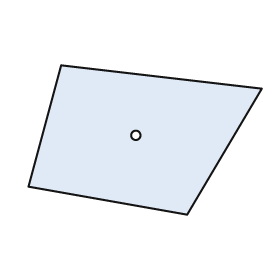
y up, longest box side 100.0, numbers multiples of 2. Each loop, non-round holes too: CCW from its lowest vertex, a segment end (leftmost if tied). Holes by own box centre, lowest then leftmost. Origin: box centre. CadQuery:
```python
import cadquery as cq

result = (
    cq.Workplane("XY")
    .moveTo(18.0, -32.0)
    .lineTo(50.0, 22.0)
    .lineTo(-36.0, 32.0)
    .lineTo(-50.0, -20.0)
    .close()
    .moveTo(-4.0, 2.0)
    .circle(2.0)
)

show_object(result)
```